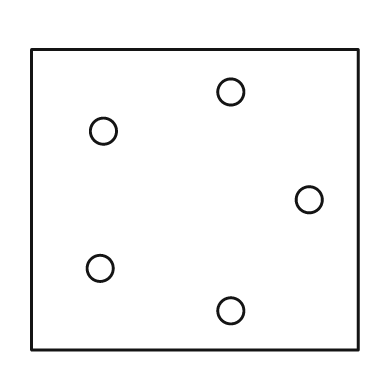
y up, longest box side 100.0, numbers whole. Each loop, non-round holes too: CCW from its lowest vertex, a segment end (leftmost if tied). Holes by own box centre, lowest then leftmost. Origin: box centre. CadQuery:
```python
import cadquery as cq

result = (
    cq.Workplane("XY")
    .moveTo(-50.0, -46.0)
    .lineTo(50.0, -46.0)
    .lineTo(50.0, 46.0)
    .lineTo(-50.0, 46.0)
    .close()
    .moveTo(11.0, -34.0)
    .circle(4.0)
    .moveTo(-29.0, -21.0)
    .circle(4.0)
    .moveTo(35.0, 0.0)
    .circle(4.0)
    .moveTo(-28.0, 21.0)
    .circle(4.0)
    .moveTo(11.0, 33.0)
    .circle(4.0)
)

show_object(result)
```